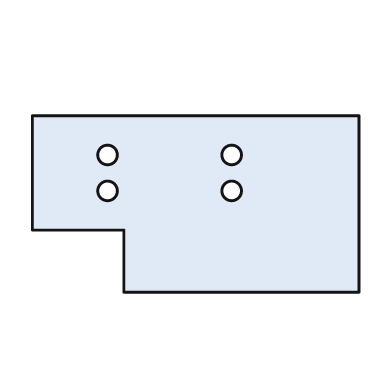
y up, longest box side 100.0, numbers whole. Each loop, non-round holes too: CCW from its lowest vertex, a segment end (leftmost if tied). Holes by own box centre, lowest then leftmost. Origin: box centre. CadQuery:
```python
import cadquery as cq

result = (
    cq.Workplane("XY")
    .moveTo(-22.0, -27.0)
    .lineTo(50.0, -27.0)
    .lineTo(50.0, 27.0)
    .lineTo(-50.0, 27.0)
    .lineTo(-50.0, -8.0)
    .lineTo(-22.0, -8.0)
    .close()
    .moveTo(-27.0, 4.0)
    .circle(3.0)
    .moveTo(11.0, 4.0)
    .circle(3.0)
    .moveTo(-27.0, 15.0)
    .circle(3.0)
    .moveTo(11.0, 15.0)
    .circle(3.0)
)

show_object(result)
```